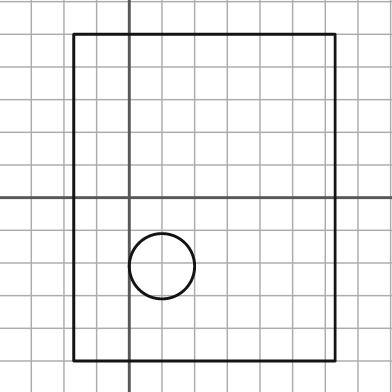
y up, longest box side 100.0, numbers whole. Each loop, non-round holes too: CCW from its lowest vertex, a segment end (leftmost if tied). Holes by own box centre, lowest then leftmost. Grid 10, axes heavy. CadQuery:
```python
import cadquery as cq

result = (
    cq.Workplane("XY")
    .moveTo(-17.0, -50.0)
    .lineTo(63.0, -50.0)
    .lineTo(63.0, 50.0)
    .lineTo(-17.0, 50.0)
    .close()
    .moveTo(10.0, -21.0)
    .circle(10.0)
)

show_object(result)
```